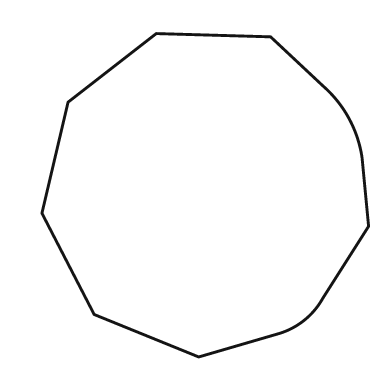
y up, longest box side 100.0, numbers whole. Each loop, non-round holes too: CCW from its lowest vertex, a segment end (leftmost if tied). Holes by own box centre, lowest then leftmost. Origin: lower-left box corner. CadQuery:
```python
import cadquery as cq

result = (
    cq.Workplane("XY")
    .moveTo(48.0, 0.0)
    .lineTo(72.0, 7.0)
    .threePointArc((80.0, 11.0), (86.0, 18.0))
    .lineTo(100.0, 40.0)
    .lineTo(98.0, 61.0)
    .threePointArc((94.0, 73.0), (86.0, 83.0))
    .lineTo(70.0, 98.0)
    .lineTo(35.0, 99.0)
    .lineTo(8.0, 78.0)
    .lineTo(0.0, 44.0)
    .lineTo(16.0, 13.0)
    .close()
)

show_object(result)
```